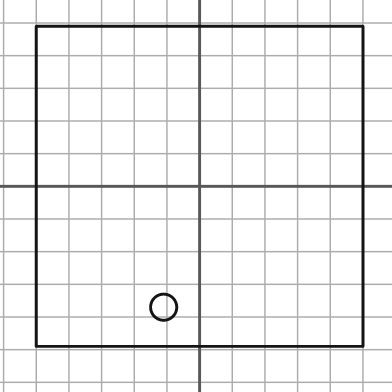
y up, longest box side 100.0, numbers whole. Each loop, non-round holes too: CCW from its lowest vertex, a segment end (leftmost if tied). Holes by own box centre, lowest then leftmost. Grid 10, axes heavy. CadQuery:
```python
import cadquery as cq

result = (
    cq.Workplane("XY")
    .moveTo(-50.0, -49.0)
    .lineTo(50.0, -49.0)
    .lineTo(50.0, 49.0)
    .lineTo(-50.0, 49.0)
    .close()
    .moveTo(-11.0, -37.0)
    .circle(4.0)
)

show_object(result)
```